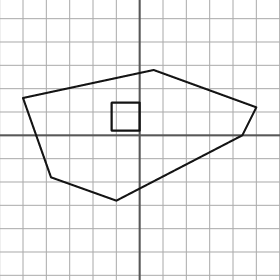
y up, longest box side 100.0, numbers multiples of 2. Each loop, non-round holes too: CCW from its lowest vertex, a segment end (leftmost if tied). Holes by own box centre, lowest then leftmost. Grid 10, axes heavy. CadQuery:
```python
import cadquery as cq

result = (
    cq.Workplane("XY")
    .moveTo(-10.0, -28.0)
    .lineTo(44.0, 0.0)
    .lineTo(50.0, 12.0)
    .lineTo(6.0, 28.0)
    .lineTo(-50.0, 16.0)
    .lineTo(-38.0, -18.0)
    .close()
    .moveTo(-12.0, 2.0)
    .lineTo(0.0, 2.0)
    .lineTo(0.0, 14.0)
    .lineTo(-12.0, 14.0)
    .close()
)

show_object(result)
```